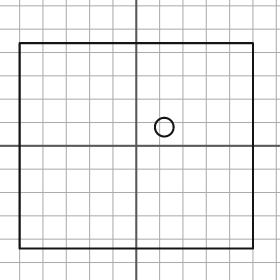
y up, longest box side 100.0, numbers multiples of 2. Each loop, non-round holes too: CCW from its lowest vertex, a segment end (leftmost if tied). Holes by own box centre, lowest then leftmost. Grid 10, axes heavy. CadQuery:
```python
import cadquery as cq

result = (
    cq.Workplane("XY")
    .moveTo(-50.0, -44.0)
    .lineTo(50.0, -44.0)
    .lineTo(50.0, 44.0)
    .lineTo(-50.0, 44.0)
    .close()
    .moveTo(12.0, 8.0)
    .circle(4.0)
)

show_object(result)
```